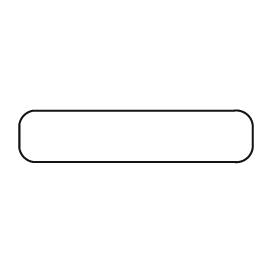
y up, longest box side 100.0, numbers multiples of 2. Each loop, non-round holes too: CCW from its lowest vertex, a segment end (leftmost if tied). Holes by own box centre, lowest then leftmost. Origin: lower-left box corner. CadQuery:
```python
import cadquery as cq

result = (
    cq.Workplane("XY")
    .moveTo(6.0, 0.0)
    .lineTo(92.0, 0.0)
    .threePointArc((98.0, 2.0), (100.0, 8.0))
    .lineTo(100.0, 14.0)
    .threePointArc((98.0, 20.0), (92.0, 22.0))
    .lineTo(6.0, 22.0)
    .threePointArc((2.0, 20.0), (0.0, 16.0))
    .lineTo(0.0, 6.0)
    .threePointArc((2.0, 2.0), (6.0, 0.0))
    .close()
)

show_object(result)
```